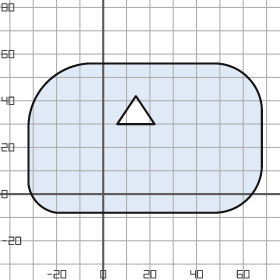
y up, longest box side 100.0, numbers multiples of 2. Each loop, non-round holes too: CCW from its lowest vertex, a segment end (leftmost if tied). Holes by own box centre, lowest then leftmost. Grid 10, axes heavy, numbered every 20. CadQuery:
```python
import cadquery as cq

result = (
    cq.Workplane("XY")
    .moveTo(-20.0, -8.0)
    .lineTo(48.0, -8.0)
    .threePointArc((62.0, -2.0), (68.0, 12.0))
    .lineTo(68.0, 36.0)
    .threePointArc((62.0, 50.0), (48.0, 56.0))
    .lineTo(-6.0, 56.0)
    .threePointArc((-24.0, 48.0), (-32.0, 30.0))
    .lineTo(-32.0, 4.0)
    .threePointArc((-28.0, -4.0), (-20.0, -8.0))
    .close()
    .moveTo(6.0, 30.0)
    .lineTo(22.0, 30.0)
    .lineTo(14.0, 42.0)
    .close()
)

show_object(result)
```